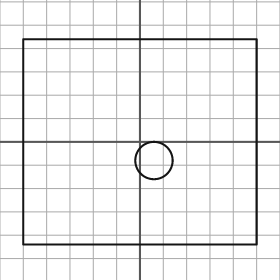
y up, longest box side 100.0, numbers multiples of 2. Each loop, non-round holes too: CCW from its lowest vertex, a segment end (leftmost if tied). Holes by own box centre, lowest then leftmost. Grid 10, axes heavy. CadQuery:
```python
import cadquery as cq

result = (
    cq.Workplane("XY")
    .moveTo(-50.0, -44.0)
    .lineTo(50.0, -44.0)
    .lineTo(50.0, 44.0)
    .lineTo(-50.0, 44.0)
    .close()
    .moveTo(6.0, -8.0)
    .circle(8.0)
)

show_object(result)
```